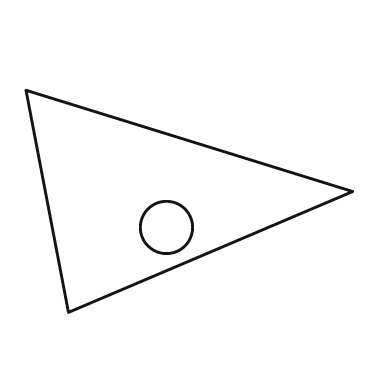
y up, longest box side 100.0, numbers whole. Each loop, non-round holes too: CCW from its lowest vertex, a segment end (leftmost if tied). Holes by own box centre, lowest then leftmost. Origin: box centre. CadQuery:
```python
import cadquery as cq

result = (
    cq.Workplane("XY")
    .moveTo(-37.0, -34.0)
    .lineTo(50.0, 3.0)
    .lineTo(-50.0, 34.0)
    .close()
    .moveTo(-7.0, -8.0)
    .circle(8.0)
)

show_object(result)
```